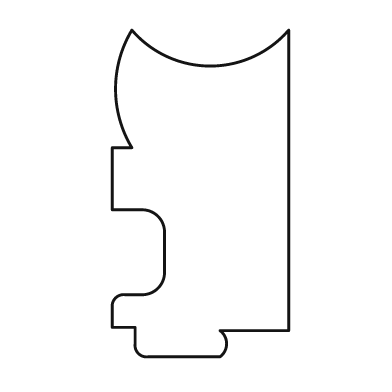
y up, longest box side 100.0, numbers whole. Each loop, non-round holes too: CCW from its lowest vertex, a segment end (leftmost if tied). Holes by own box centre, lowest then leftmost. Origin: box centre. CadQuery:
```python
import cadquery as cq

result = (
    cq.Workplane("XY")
    .moveTo(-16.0, -50.0)
    .lineTo(6.0, -50.0)
    .threePointArc((8.0, -46.0), (6.0, -42.0))
    .lineTo(27.0, -42.0)
    .lineTo(27.0, 50.0)
    .threePointArc((3.0, 39.0), (-21.0, 50.0))
    .threePointArc((-26.0, 32.0), (-21.0, 14.0))
    .lineTo(-27.0, 14.0)
    .lineTo(-27.0, -5.0)
    .lineTo(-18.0, -5.0)
    .threePointArc((-13.0, -7.0), (-11.0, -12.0))
    .lineTo(-11.0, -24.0)
    .threePointArc((-13.0, -29.0), (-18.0, -31.0))
    .lineTo(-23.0, -31.0)
    .threePointArc((-26.0, -32.0), (-27.0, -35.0))
    .lineTo(-27.0, -41.0)
    .lineTo(-20.0, -41.0)
    .lineTo(-20.0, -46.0)
    .threePointArc((-19.0, -49.0), (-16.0, -50.0))
    .close()
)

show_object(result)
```